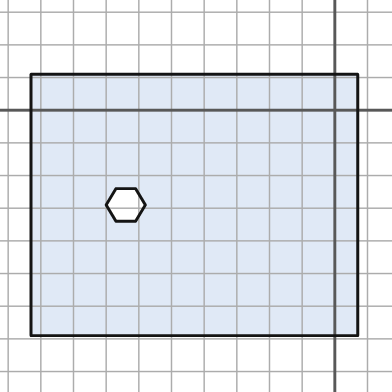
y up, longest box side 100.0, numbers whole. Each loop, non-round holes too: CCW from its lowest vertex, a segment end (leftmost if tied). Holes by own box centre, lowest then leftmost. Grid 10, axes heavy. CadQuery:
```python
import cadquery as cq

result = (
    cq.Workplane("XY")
    .moveTo(-93.0, -69.0)
    .lineTo(7.0, -69.0)
    .lineTo(7.0, 11.0)
    .lineTo(-93.0, 11.0)
    .close()
    .moveTo(-67.0, -34.0)
    .lineTo(-61.0, -34.0)
    .lineTo(-58.0, -29.0)
    .lineTo(-61.0, -24.0)
    .lineTo(-67.0, -24.0)
    .lineTo(-70.0, -29.0)
    .close()
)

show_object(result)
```